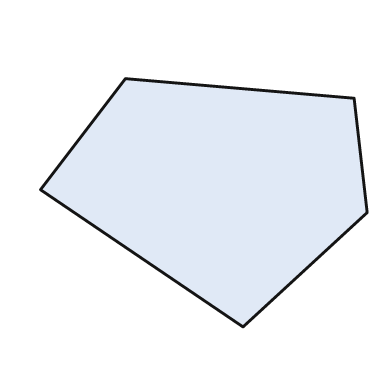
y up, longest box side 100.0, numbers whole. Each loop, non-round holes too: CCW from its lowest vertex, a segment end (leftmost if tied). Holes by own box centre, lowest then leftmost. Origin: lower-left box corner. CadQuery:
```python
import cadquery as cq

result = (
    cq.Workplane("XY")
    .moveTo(62.0, 0.0)
    .lineTo(100.0, 35.0)
    .lineTo(96.0, 70.0)
    .lineTo(26.0, 76.0)
    .lineTo(0.0, 42.0)
    .close()
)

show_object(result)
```